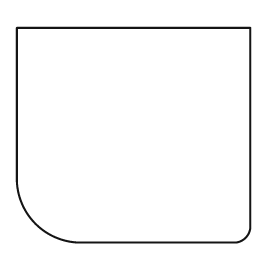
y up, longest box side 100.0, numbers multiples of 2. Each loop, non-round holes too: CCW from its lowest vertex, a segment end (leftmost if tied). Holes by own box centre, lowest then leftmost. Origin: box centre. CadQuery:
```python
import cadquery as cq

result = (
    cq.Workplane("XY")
    .moveTo(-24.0, -46.0)
    .lineTo(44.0, -46.0)
    .threePointArc((48.0, -44.0), (50.0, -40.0))
    .lineTo(50.0, 46.0)
    .lineTo(-50.0, 46.0)
    .lineTo(-50.0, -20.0)
    .threePointArc((-42.0, -38.0), (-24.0, -46.0))
    .close()
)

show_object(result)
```